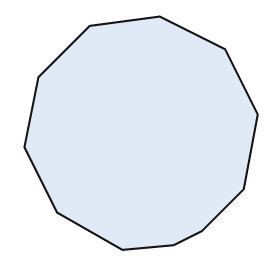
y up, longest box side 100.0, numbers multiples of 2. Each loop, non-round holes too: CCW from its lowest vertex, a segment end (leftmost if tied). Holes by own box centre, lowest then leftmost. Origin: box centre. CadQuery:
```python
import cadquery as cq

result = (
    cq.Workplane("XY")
    .moveTo(-8.0, -50.0)
    .lineTo(14.0, -48.0)
    .lineTo(26.0, -42.0)
    .lineTo(44.0, -24.0)
    .lineTo(50.0, 8.0)
    .lineTo(36.0, 36.0)
    .lineTo(8.0, 50.0)
    .lineTo(-22.0, 46.0)
    .lineTo(-44.0, 24.0)
    .lineTo(-50.0, -6.0)
    .lineTo(-36.0, -34.0)
    .close()
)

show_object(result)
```